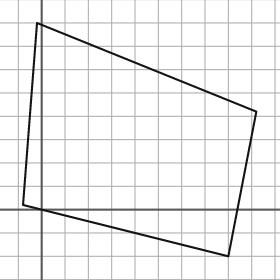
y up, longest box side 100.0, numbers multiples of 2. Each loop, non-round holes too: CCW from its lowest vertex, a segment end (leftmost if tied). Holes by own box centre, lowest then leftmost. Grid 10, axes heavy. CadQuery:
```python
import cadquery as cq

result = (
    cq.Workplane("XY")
    .moveTo(80.0, -20.0)
    .lineTo(92.0, 42.0)
    .lineTo(-2.0, 80.0)
    .lineTo(-8.0, 2.0)
    .close()
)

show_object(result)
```